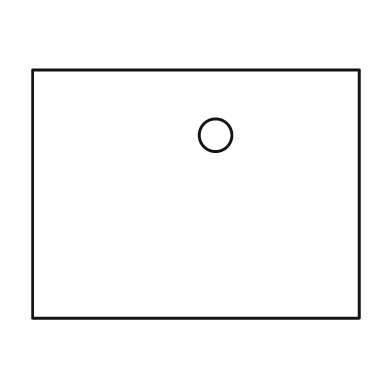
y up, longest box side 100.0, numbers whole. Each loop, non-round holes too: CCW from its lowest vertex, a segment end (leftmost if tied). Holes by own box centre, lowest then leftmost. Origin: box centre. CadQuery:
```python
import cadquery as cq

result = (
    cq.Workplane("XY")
    .moveTo(-50.0, -38.0)
    .lineTo(50.0, -38.0)
    .lineTo(50.0, 38.0)
    .lineTo(-50.0, 38.0)
    .close()
    .moveTo(6.0, 18.0)
    .circle(5.0)
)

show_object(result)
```